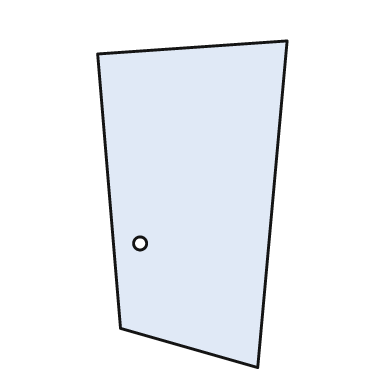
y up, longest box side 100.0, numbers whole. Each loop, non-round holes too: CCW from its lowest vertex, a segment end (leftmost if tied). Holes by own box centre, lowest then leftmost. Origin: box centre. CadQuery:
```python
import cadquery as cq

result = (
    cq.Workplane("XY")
    .moveTo(20.0, -50.0)
    .lineTo(29.0, 50.0)
    .lineTo(-29.0, 46.0)
    .lineTo(-22.0, -38.0)
    .close()
    .moveTo(-16.0, -12.0)
    .circle(2.0)
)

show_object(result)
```